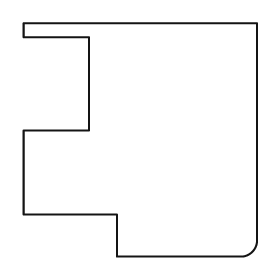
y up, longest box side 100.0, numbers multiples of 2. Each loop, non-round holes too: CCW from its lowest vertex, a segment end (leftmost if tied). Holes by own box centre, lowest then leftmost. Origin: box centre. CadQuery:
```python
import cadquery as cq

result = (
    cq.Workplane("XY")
    .moveTo(-10.0, -50.0)
    .lineTo(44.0, -50.0)
    .threePointArc((48.0, -48.0), (50.0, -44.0))
    .lineTo(50.0, 50.0)
    .lineTo(-50.0, 50.0)
    .lineTo(-50.0, 44.0)
    .lineTo(-22.0, 44.0)
    .lineTo(-22.0, 4.0)
    .lineTo(-50.0, 4.0)
    .lineTo(-50.0, -32.0)
    .lineTo(-10.0, -32.0)
    .close()
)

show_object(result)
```